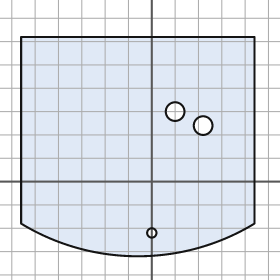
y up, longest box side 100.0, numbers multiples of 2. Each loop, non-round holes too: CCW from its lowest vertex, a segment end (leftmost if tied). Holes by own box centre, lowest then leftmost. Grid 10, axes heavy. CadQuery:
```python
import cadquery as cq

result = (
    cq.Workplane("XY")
    .moveTo(-56.0, -18.0)
    .threePointArc((-6.0, -32.0), (44.0, -18.0))
    .lineTo(44.0, 62.0)
    .lineTo(-56.0, 62.0)
    .close()
    .moveTo(0.0, -22.0)
    .circle(2.0)
    .moveTo(22.0, 24.0)
    .circle(4.0)
    .moveTo(10.0, 30.0)
    .circle(4.0)
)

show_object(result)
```